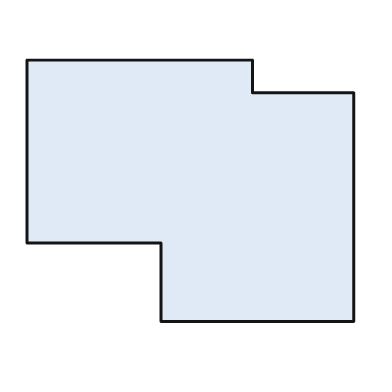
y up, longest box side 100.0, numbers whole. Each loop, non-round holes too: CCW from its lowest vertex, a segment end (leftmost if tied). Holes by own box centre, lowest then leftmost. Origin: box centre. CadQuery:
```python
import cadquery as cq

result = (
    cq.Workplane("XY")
    .moveTo(-9.0, -40.0)
    .lineTo(50.0, -40.0)
    .lineTo(50.0, 30.0)
    .lineTo(19.0, 30.0)
    .lineTo(19.0, 40.0)
    .lineTo(-50.0, 40.0)
    .lineTo(-50.0, -16.0)
    .lineTo(-9.0, -16.0)
    .close()
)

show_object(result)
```